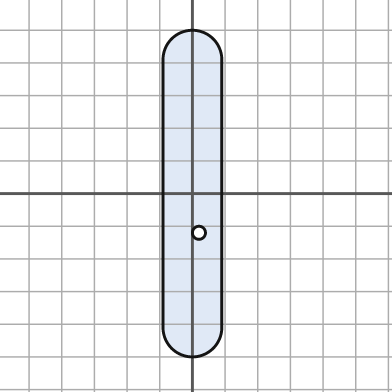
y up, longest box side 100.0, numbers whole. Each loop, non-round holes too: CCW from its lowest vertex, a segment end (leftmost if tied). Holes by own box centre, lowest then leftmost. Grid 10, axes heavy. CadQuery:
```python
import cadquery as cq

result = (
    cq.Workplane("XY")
    .moveTo(-9.0, -41.0)
    .threePointArc((0.0, -50.0), (9.0, -41.0))
    .lineTo(9.0, 41.0)
    .threePointArc((0.0, 50.0), (-9.0, 41.0))
    .close()
    .moveTo(2.0, -12.0)
    .circle(2.0)
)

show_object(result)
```